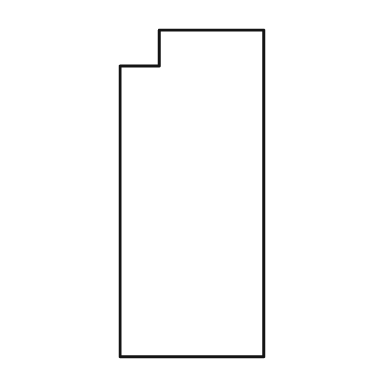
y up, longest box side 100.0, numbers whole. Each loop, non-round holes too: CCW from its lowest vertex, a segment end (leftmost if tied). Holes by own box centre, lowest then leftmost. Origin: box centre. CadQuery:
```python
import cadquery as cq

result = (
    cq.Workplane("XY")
    .moveTo(-22.0, -50.0)
    .lineTo(22.0, -50.0)
    .lineTo(22.0, 50.0)
    .lineTo(-10.0, 50.0)
    .lineTo(-10.0, 39.0)
    .lineTo(-22.0, 39.0)
    .close()
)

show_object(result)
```